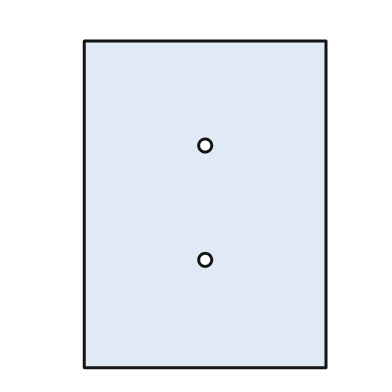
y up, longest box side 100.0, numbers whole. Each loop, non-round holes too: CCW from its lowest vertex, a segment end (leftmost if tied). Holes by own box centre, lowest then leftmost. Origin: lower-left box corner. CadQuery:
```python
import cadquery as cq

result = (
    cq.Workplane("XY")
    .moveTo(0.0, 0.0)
    .lineTo(74.0, 0.0)
    .lineTo(74.0, 100.0)
    .lineTo(0.0, 100.0)
    .close()
    .moveTo(37.0, 33.0)
    .circle(2.0)
    .moveTo(37.0, 68.0)
    .circle(2.0)
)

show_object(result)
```